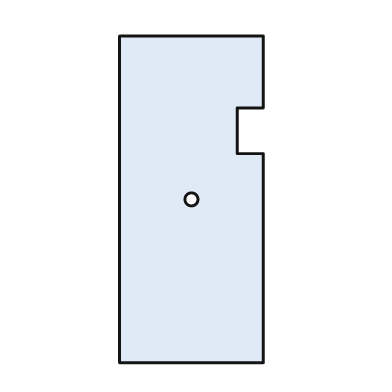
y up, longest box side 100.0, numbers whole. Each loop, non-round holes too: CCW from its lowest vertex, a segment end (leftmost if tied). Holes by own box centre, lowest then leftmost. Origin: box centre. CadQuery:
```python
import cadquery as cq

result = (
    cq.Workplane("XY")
    .moveTo(-22.0, -50.0)
    .lineTo(22.0, -50.0)
    .lineTo(22.0, 14.0)
    .lineTo(14.0, 14.0)
    .lineTo(14.0, 28.0)
    .lineTo(22.0, 28.0)
    .lineTo(22.0, 50.0)
    .lineTo(-22.0, 50.0)
    .close()
    .moveTo(0.0, 0.0)
    .circle(2.0)
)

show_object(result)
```